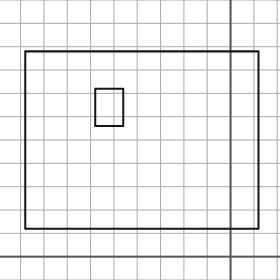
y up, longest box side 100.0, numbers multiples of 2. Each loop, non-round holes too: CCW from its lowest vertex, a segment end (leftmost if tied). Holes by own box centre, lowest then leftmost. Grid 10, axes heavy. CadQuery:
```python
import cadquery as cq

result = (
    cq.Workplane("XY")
    .moveTo(-88.0, 12.0)
    .lineTo(12.0, 12.0)
    .lineTo(12.0, 88.0)
    .lineTo(-88.0, 88.0)
    .close()
    .moveTo(-58.0, 56.0)
    .lineTo(-46.0, 56.0)
    .lineTo(-46.0, 72.0)
    .lineTo(-58.0, 72.0)
    .close()
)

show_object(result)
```